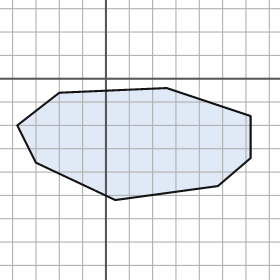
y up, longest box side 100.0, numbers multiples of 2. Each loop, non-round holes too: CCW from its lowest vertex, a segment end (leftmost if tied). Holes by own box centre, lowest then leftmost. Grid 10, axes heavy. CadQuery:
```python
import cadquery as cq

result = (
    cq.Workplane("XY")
    .moveTo(4.0, -52.0)
    .lineTo(48.0, -46.0)
    .lineTo(62.0, -34.0)
    .lineTo(62.0, -16.0)
    .lineTo(26.0, -4.0)
    .lineTo(-20.0, -6.0)
    .lineTo(-38.0, -20.0)
    .lineTo(-30.0, -36.0)
    .close()
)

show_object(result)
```